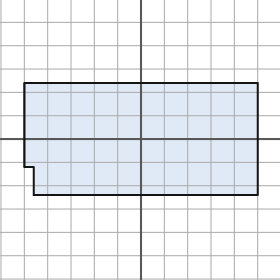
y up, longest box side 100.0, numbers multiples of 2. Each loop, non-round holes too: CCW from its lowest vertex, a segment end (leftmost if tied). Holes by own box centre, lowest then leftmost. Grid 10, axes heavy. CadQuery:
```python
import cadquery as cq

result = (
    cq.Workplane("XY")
    .moveTo(-46.0, -24.0)
    .lineTo(50.0, -24.0)
    .lineTo(50.0, 24.0)
    .lineTo(-50.0, 24.0)
    .lineTo(-50.0, -12.0)
    .lineTo(-46.0, -12.0)
    .close()
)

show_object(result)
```